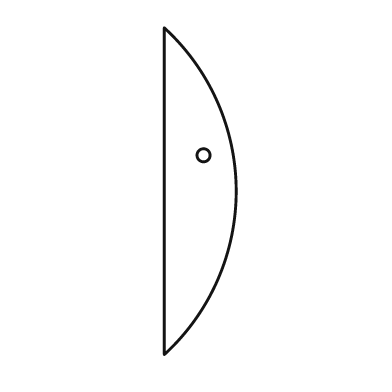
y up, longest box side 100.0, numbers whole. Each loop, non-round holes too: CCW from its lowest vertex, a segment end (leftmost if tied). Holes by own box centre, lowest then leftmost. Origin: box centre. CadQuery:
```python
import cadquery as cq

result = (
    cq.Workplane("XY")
    .moveTo(-11.0, -50.0)
    .threePointArc((11.0, 0.0), (-11.0, 50.0))
    .close()
    .moveTo(1.0, 11.0)
    .circle(2.0)
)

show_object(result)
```